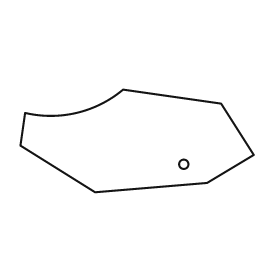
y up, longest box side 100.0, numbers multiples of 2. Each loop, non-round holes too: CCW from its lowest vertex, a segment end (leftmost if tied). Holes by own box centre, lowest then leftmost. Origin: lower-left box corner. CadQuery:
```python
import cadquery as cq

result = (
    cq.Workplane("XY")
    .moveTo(32.0, 0.0)
    .lineTo(80.0, 4.0)
    .lineTo(100.0, 16.0)
    .lineTo(86.0, 38.0)
    .lineTo(44.0, 44.0)
    .threePointArc((24.0, 34.0), (2.0, 34.0))
    .lineTo(0.0, 20.0)
    .close()
    .moveTo(70.0, 12.0)
    .circle(2.0)
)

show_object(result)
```